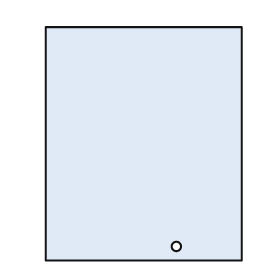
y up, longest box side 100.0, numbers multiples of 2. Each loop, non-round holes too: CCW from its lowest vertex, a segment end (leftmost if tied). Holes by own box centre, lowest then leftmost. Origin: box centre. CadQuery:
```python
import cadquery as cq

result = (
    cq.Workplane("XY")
    .moveTo(-42.0, -50.0)
    .lineTo(42.0, -50.0)
    .lineTo(42.0, 50.0)
    .lineTo(-42.0, 50.0)
    .close()
    .moveTo(14.0, -44.0)
    .circle(2.0)
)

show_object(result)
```